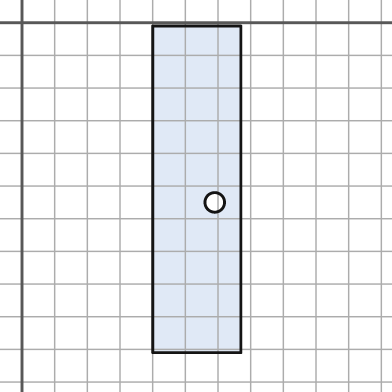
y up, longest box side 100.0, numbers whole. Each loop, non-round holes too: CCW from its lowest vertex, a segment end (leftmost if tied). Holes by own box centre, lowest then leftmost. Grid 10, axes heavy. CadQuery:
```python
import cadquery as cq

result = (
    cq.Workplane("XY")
    .moveTo(40.0, -101.0)
    .lineTo(67.0, -101.0)
    .lineTo(67.0, -1.0)
    .lineTo(40.0, -1.0)
    .close()
    .moveTo(59.0, -55.0)
    .circle(3.0)
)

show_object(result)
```